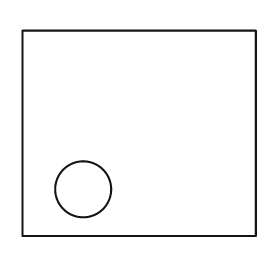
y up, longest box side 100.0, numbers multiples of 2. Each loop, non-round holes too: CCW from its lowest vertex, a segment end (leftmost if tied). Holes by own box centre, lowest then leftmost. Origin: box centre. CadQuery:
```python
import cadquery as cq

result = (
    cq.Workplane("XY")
    .moveTo(-50.0, -44.0)
    .lineTo(50.0, -44.0)
    .lineTo(50.0, 44.0)
    .lineTo(-50.0, 44.0)
    .close()
    .moveTo(-24.0, -24.0)
    .circle(12.0)
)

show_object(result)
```